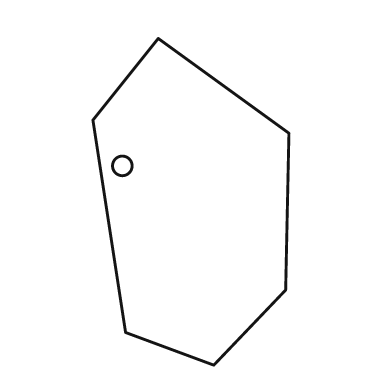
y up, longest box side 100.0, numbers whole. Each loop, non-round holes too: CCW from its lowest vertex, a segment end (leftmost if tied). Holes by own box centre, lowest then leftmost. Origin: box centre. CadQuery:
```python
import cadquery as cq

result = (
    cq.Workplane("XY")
    .moveTo(7.0, -50.0)
    .lineTo(29.0, -27.0)
    .lineTo(30.0, 21.0)
    .lineTo(-10.0, 50.0)
    .lineTo(-30.0, 25.0)
    .lineTo(-20.0, -40.0)
    .close()
    .moveTo(-21.0, 11.0)
    .circle(3.0)
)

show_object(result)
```